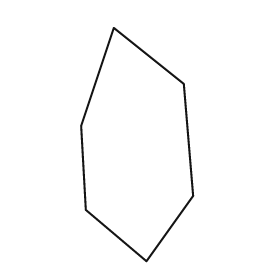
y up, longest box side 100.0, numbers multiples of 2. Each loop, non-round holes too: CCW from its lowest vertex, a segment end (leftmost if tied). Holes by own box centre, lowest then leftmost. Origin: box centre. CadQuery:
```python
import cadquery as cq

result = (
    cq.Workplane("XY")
    .moveTo(4.0, -50.0)
    .lineTo(24.0, -22.0)
    .lineTo(20.0, 26.0)
    .lineTo(-10.0, 50.0)
    .lineTo(-24.0, 8.0)
    .lineTo(-22.0, -28.0)
    .close()
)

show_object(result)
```